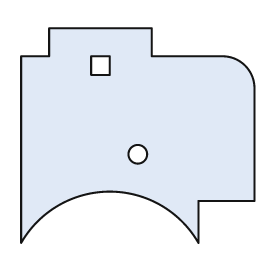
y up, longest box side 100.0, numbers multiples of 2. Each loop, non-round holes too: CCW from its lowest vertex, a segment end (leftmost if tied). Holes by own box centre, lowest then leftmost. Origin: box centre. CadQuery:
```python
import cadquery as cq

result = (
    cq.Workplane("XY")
    .moveTo(-50.0, -46.0)
    .threePointArc((-12.0, -24.0), (26.0, -46.0))
    .lineTo(26.0, -28.0)
    .lineTo(50.0, -28.0)
    .lineTo(50.0, 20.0)
    .threePointArc((46.0, 30.0), (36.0, 34.0))
    .lineTo(6.0, 34.0)
    .lineTo(6.0, 46.0)
    .lineTo(-38.0, 46.0)
    .lineTo(-38.0, 34.0)
    .lineTo(-50.0, 34.0)
    .close()
    .moveTo(0.0, -8.0)
    .circle(4.0)
    .moveTo(-20.0, 26.0)
    .lineTo(-12.0, 26.0)
    .lineTo(-12.0, 34.0)
    .lineTo(-20.0, 34.0)
    .close()
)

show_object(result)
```